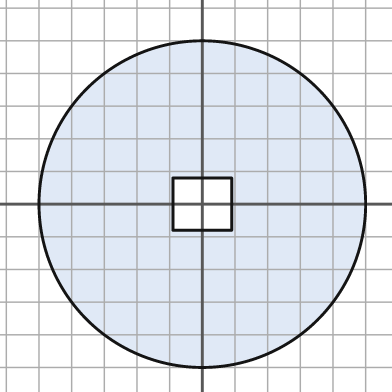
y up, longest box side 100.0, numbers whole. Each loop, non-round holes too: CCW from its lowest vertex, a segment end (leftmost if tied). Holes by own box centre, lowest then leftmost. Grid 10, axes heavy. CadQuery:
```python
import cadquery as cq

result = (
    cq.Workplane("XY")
    .moveTo(0.0, 0.0)
    .circle(50.0)
    .moveTo(-9.0, -8.0)
    .lineTo(9.0, -8.0)
    .lineTo(9.0, 8.0)
    .lineTo(-9.0, 8.0)
    .close()
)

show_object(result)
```